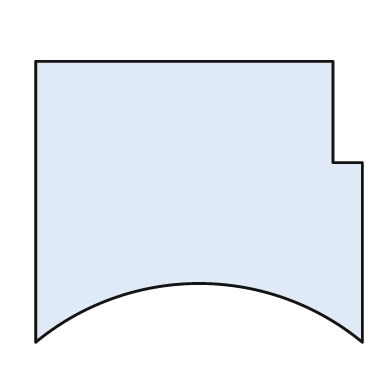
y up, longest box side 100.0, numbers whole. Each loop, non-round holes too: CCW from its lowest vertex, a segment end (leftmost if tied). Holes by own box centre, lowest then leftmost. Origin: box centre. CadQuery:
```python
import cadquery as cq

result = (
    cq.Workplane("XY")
    .moveTo(-50.0, -43.0)
    .threePointArc((0.0, -25.0), (50.0, -43.0))
    .lineTo(50.0, 12.0)
    .lineTo(41.0, 12.0)
    .lineTo(41.0, 43.0)
    .lineTo(-50.0, 43.0)
    .close()
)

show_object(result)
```